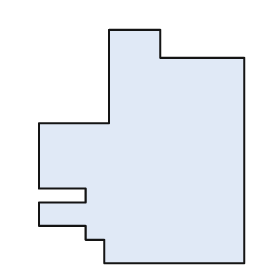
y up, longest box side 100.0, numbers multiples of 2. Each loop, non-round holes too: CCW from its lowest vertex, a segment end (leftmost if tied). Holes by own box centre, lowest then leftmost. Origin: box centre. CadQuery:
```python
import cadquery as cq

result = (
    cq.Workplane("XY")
    .moveTo(-16.0, -50.0)
    .lineTo(44.0, -50.0)
    .lineTo(44.0, 38.0)
    .lineTo(8.0, 38.0)
    .lineTo(8.0, 50.0)
    .lineTo(-14.0, 50.0)
    .lineTo(-14.0, 10.0)
    .lineTo(-44.0, 10.0)
    .lineTo(-44.0, -18.0)
    .lineTo(-24.0, -18.0)
    .lineTo(-24.0, -24.0)
    .lineTo(-44.0, -24.0)
    .lineTo(-44.0, -34.0)
    .lineTo(-24.0, -34.0)
    .lineTo(-24.0, -40.0)
    .lineTo(-16.0, -40.0)
    .close()
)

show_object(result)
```